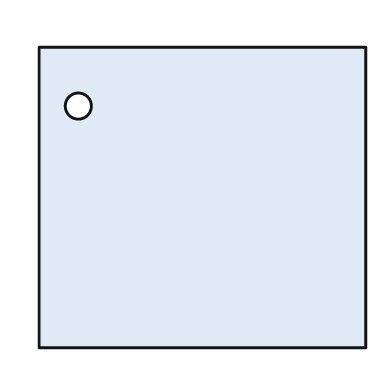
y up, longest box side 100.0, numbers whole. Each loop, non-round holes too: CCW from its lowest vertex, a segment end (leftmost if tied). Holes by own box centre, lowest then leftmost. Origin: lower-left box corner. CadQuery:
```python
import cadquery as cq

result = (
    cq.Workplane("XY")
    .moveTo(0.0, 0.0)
    .lineTo(100.0, 0.0)
    .lineTo(100.0, 92.0)
    .lineTo(0.0, 92.0)
    .close()
    .moveTo(12.0, 74.0)
    .circle(4.0)
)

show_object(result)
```